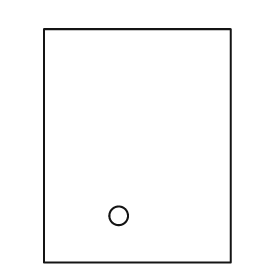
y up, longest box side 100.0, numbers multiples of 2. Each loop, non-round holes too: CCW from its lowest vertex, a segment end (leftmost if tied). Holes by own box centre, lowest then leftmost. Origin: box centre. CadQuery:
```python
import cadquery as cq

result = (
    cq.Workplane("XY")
    .moveTo(-40.0, -50.0)
    .lineTo(40.0, -50.0)
    .lineTo(40.0, 50.0)
    .lineTo(-40.0, 50.0)
    .close()
    .moveTo(-8.0, -30.0)
    .circle(4.0)
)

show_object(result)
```